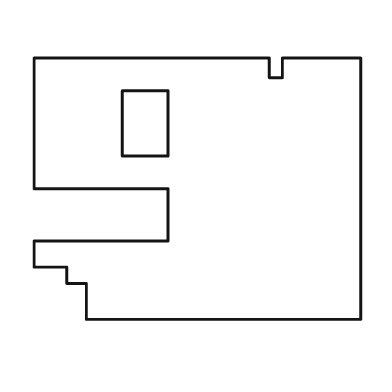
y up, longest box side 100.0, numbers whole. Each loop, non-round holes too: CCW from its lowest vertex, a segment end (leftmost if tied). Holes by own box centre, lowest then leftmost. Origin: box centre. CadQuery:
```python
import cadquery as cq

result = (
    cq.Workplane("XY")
    .moveTo(-34.0, -40.0)
    .lineTo(50.0, -40.0)
    .lineTo(50.0, 40.0)
    .lineTo(26.0, 40.0)
    .lineTo(26.0, 34.0)
    .lineTo(22.0, 34.0)
    .lineTo(22.0, 40.0)
    .lineTo(-50.0, 40.0)
    .lineTo(-50.0, 0.0)
    .lineTo(-9.0, 0.0)
    .lineTo(-9.0, -16.0)
    .lineTo(-50.0, -16.0)
    .lineTo(-50.0, -24.0)
    .lineTo(-40.0, -24.0)
    .lineTo(-40.0, -29.0)
    .lineTo(-34.0, -29.0)
    .close()
    .moveTo(-23.0, 10.0)
    .lineTo(-9.0, 10.0)
    .lineTo(-9.0, 30.0)
    .lineTo(-23.0, 30.0)
    .close()
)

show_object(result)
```